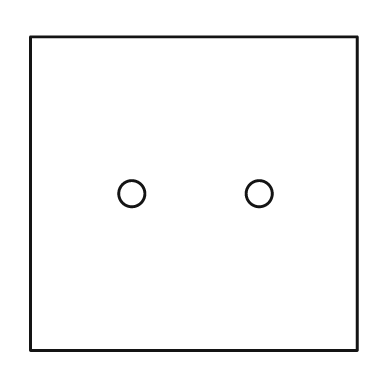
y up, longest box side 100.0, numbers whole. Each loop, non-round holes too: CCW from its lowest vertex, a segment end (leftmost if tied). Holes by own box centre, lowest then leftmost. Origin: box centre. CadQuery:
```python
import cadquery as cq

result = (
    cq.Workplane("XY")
    .moveTo(-50.0, -48.0)
    .lineTo(50.0, -48.0)
    .lineTo(50.0, 48.0)
    .lineTo(-50.0, 48.0)
    .close()
    .moveTo(-19.0, 0.0)
    .circle(4.0)
    .moveTo(20.0, 0.0)
    .circle(4.0)
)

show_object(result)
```